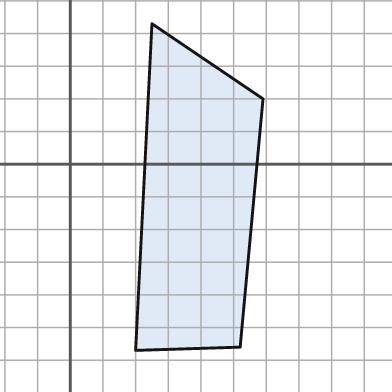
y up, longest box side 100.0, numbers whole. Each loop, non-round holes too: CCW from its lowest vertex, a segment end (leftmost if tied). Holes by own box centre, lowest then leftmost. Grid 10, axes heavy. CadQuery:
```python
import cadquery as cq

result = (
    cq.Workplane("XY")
    .moveTo(20.0, -57.0)
    .lineTo(52.0, -56.0)
    .lineTo(59.0, 20.0)
    .lineTo(25.0, 43.0)
    .close()
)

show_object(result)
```